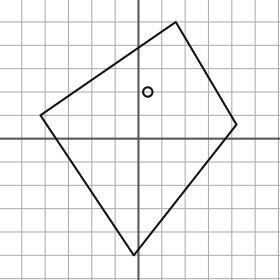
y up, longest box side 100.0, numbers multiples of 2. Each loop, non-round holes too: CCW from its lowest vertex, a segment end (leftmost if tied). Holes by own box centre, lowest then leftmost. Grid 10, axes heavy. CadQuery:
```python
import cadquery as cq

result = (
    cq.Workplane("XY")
    .moveTo(-2.0, -50.0)
    .lineTo(42.0, 6.0)
    .lineTo(16.0, 50.0)
    .lineTo(-42.0, 10.0)
    .close()
    .moveTo(4.0, 20.0)
    .circle(2.0)
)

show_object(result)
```